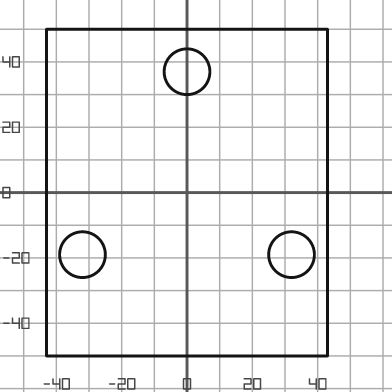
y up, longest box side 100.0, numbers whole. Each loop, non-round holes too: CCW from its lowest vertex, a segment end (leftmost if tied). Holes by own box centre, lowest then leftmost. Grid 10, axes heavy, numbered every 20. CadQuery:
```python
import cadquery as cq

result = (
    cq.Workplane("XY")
    .moveTo(-43.0, -50.0)
    .lineTo(43.0, -50.0)
    .lineTo(43.0, 50.0)
    .lineTo(-43.0, 50.0)
    .close()
    .moveTo(-32.0, -19.0)
    .circle(7.0)
    .moveTo(32.0, -19.0)
    .circle(7.0)
    .moveTo(0.0, 37.0)
    .circle(7.0)
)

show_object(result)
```